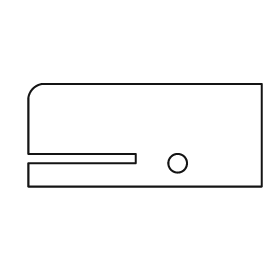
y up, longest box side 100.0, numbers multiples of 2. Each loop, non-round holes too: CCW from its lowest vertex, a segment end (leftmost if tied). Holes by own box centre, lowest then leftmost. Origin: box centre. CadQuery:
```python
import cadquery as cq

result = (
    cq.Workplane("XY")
    .moveTo(-50.0, -22.0)
    .lineTo(50.0, -22.0)
    .lineTo(50.0, 22.0)
    .lineTo(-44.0, 22.0)
    .threePointArc((-48.0, 20.0), (-50.0, 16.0))
    .lineTo(-50.0, -8.0)
    .lineTo(-4.0, -8.0)
    .lineTo(-4.0, -12.0)
    .lineTo(-50.0, -12.0)
    .close()
    .moveTo(14.0, -12.0)
    .circle(4.0)
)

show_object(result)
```